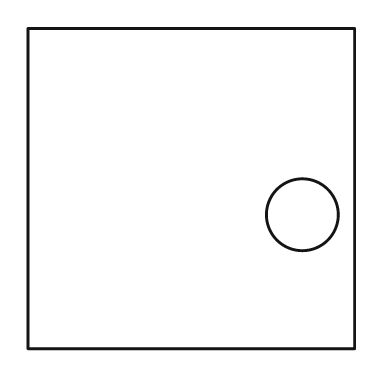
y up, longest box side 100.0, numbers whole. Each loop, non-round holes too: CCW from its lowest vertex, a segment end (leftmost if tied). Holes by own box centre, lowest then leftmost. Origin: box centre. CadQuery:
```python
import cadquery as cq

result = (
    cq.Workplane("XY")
    .moveTo(-50.0, -49.0)
    .lineTo(50.0, -49.0)
    .lineTo(50.0, 49.0)
    .lineTo(-50.0, 49.0)
    .close()
    .moveTo(34.0, -8.0)
    .circle(11.0)
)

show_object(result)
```